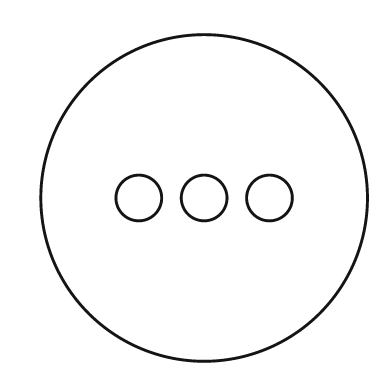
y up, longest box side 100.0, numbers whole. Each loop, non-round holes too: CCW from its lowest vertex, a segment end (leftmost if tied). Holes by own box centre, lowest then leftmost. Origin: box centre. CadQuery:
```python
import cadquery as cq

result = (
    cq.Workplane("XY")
    .moveTo(0.0, 0.0)
    .circle(50.0)
    .moveTo(-20.0, 0.0)
    .circle(7.0)
    .moveTo(0.0, 0.0)
    .circle(7.0)
    .moveTo(20.0, 0.0)
    .circle(7.0)
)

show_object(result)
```